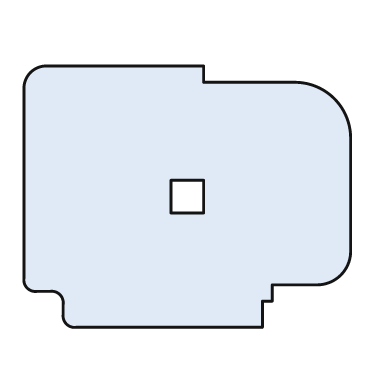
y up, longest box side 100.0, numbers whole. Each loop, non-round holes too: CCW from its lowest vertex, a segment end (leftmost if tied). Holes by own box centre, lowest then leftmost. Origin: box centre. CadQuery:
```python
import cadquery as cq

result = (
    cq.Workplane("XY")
    .moveTo(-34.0, -40.0)
    .lineTo(23.0, -40.0)
    .lineTo(23.0, -32.0)
    .lineTo(26.0, -32.0)
    .lineTo(26.0, -27.0)
    .lineTo(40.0, -27.0)
    .threePointArc((47.0, -24.0), (50.0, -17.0))
    .lineTo(50.0, 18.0)
    .threePointArc((45.0, 30.0), (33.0, 35.0))
    .lineTo(5.0, 35.0)
    .lineTo(5.0, 40.0)
    .lineTo(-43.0, 40.0)
    .threePointArc((-48.0, 38.0), (-50.0, 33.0))
    .lineTo(-50.0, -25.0)
    .threePointArc((-49.0, -28.0), (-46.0, -29.0))
    .lineTo(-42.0, -29.0)
    .threePointArc((-39.0, -30.0), (-38.0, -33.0))
    .lineTo(-38.0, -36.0)
    .threePointArc((-37.0, -39.0), (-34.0, -40.0))
    .close()
    .moveTo(-5.0, -5.0)
    .lineTo(5.0, -5.0)
    .lineTo(5.0, 5.0)
    .lineTo(-5.0, 5.0)
    .close()
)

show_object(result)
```